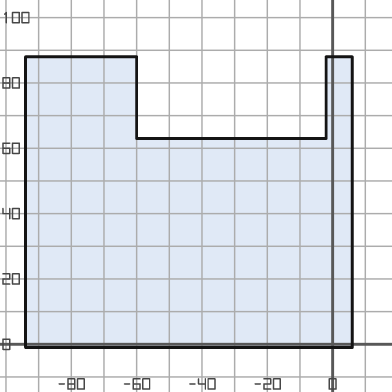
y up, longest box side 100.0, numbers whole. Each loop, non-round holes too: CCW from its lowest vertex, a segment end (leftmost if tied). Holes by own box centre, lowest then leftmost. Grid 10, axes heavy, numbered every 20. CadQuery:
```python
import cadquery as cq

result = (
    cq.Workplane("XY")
    .moveTo(-94.0, -1.0)
    .lineTo(6.0, -1.0)
    .lineTo(6.0, 88.0)
    .lineTo(-2.0, 88.0)
    .lineTo(-2.0, 63.0)
    .lineTo(-60.0, 63.0)
    .lineTo(-60.0, 88.0)
    .lineTo(-94.0, 88.0)
    .close()
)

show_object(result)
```